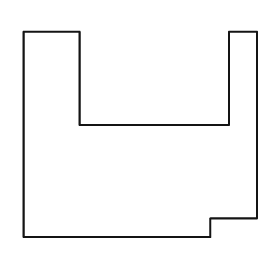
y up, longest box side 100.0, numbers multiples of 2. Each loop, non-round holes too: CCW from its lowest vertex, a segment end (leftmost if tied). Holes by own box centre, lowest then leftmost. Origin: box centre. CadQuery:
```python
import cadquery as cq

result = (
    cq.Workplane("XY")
    .moveTo(-50.0, -44.0)
    .lineTo(30.0, -44.0)
    .lineTo(30.0, -36.0)
    .lineTo(50.0, -36.0)
    .lineTo(50.0, 44.0)
    .lineTo(38.0, 44.0)
    .lineTo(38.0, 4.0)
    .lineTo(-26.0, 4.0)
    .lineTo(-26.0, 44.0)
    .lineTo(-50.0, 44.0)
    .close()
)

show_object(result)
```